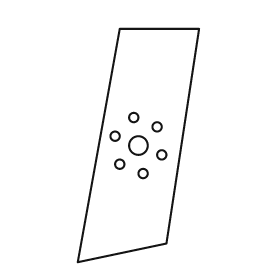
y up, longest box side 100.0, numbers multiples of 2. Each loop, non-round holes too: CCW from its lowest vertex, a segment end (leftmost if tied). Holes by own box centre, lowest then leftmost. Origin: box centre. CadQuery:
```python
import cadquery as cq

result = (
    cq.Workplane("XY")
    .moveTo(-26.0, -50.0)
    .lineTo(12.0, -42.0)
    .lineTo(26.0, 50.0)
    .lineTo(-8.0, 50.0)
    .close()
    .moveTo(2.0, -12.0)
    .circle(2.0)
    .moveTo(-8.0, -8.0)
    .circle(2.0)
    .moveTo(10.0, -4.0)
    .circle(2.0)
    .moveTo(0.0, 0.0)
    .circle(4.0)
    .moveTo(-10.0, 4.0)
    .circle(2.0)
    .moveTo(8.0, 8.0)
    .circle(2.0)
    .moveTo(-2.0, 12.0)
    .circle(2.0)
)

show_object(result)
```